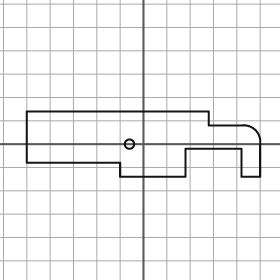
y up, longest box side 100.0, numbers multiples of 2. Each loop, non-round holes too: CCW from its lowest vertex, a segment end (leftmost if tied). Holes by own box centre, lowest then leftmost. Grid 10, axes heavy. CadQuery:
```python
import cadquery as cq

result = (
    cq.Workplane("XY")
    .moveTo(-10.0, -14.0)
    .lineTo(18.0, -14.0)
    .lineTo(18.0, -2.0)
    .lineTo(42.0, -2.0)
    .lineTo(42.0, -14.0)
    .lineTo(50.0, -14.0)
    .lineTo(50.0, 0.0)
    .threePointArc((48.0, 6.0), (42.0, 8.0))
    .lineTo(28.0, 8.0)
    .lineTo(28.0, 14.0)
    .lineTo(-50.0, 14.0)
    .lineTo(-50.0, -8.0)
    .lineTo(-10.0, -8.0)
    .close()
    .moveTo(-6.0, 0.0)
    .circle(2.0)
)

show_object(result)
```